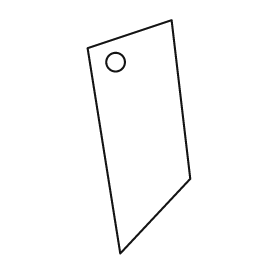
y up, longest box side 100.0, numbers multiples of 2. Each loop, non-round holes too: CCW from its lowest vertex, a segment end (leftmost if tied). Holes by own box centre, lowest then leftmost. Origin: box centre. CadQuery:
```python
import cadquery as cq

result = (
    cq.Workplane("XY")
    .moveTo(-8.0, -50.0)
    .lineTo(22.0, -18.0)
    .lineTo(14.0, 50.0)
    .lineTo(-22.0, 38.0)
    .close()
    .moveTo(-10.0, 32.0)
    .circle(4.0)
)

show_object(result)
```